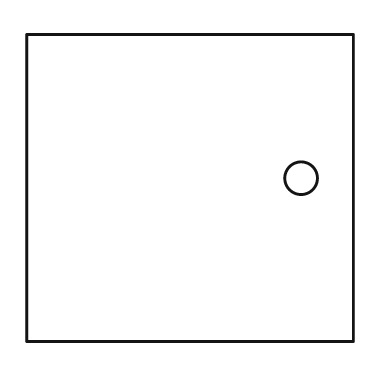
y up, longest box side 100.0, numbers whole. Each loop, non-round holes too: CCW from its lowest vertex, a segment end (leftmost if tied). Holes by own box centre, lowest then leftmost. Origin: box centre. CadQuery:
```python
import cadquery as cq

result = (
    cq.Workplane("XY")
    .moveTo(-50.0, -47.0)
    .lineTo(50.0, -47.0)
    .lineTo(50.0, 47.0)
    .lineTo(-50.0, 47.0)
    .close()
    .moveTo(34.0, 3.0)
    .circle(5.0)
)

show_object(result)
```